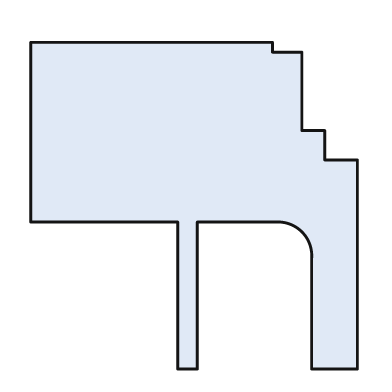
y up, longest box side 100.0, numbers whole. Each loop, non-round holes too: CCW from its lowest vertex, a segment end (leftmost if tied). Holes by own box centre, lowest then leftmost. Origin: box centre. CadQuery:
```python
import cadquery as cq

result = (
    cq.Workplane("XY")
    .moveTo(-5.0, -50.0)
    .lineTo(1.0, -50.0)
    .lineTo(1.0, -5.0)
    .lineTo(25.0, -5.0)
    .threePointArc((33.0, -8.0), (36.0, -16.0))
    .lineTo(36.0, -50.0)
    .lineTo(50.0, -50.0)
    .lineTo(50.0, 14.0)
    .lineTo(40.0, 14.0)
    .lineTo(40.0, 23.0)
    .lineTo(33.0, 23.0)
    .lineTo(33.0, 47.0)
    .lineTo(24.0, 47.0)
    .lineTo(24.0, 50.0)
    .lineTo(-50.0, 50.0)
    .lineTo(-50.0, -5.0)
    .lineTo(-5.0, -5.0)
    .close()
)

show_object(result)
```